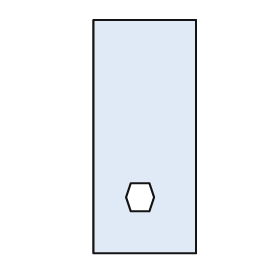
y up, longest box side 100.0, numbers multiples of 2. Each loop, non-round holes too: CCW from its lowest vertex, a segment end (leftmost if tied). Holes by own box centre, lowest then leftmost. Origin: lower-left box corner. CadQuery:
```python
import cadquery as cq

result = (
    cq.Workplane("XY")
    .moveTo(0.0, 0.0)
    .lineTo(44.0, 0.0)
    .lineTo(44.0, 100.0)
    .lineTo(0.0, 100.0)
    .close()
    .moveTo(16.0, 18.0)
    .lineTo(24.0, 18.0)
    .lineTo(26.0, 24.0)
    .lineTo(24.0, 30.0)
    .lineTo(16.0, 30.0)
    .lineTo(14.0, 24.0)
    .close()
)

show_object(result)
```